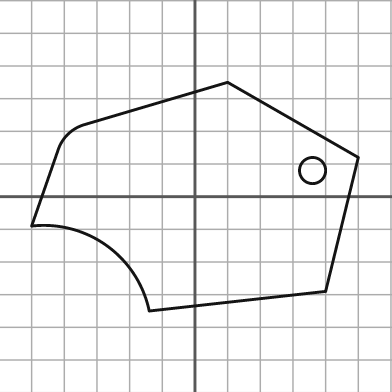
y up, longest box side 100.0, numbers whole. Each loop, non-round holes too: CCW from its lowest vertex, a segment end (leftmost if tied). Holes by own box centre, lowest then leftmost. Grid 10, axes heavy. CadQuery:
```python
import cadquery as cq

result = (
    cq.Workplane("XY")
    .moveTo(-14.0, -35.0)
    .lineTo(40.0, -29.0)
    .lineTo(50.0, 12.0)
    .lineTo(10.0, 35.0)
    .lineTo(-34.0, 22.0)
    .threePointArc((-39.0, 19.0), (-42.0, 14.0))
    .lineTo(-50.0, -9.0)
    .threePointArc((-27.0, -15.0), (-14.0, -35.0))
    .close()
    .moveTo(36.0, 8.0)
    .circle(4.0)
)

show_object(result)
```